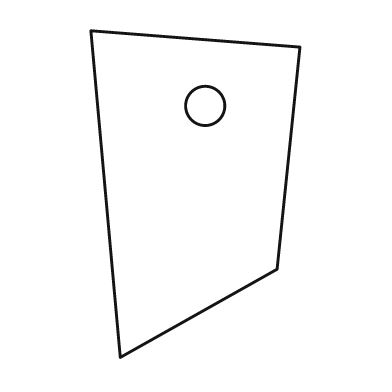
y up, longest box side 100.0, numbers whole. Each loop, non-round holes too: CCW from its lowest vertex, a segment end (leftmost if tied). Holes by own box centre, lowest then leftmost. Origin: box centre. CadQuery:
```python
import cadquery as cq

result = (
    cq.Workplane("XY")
    .moveTo(-23.0, -50.0)
    .lineTo(25.0, -23.0)
    .lineTo(32.0, 45.0)
    .lineTo(-32.0, 50.0)
    .close()
    .moveTo(3.0, 27.0)
    .circle(6.0)
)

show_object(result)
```